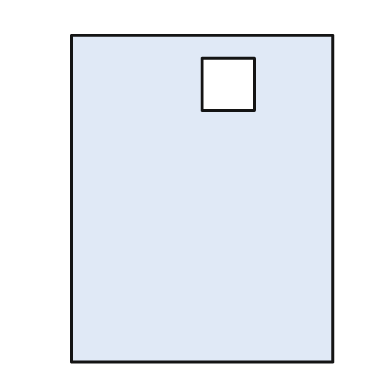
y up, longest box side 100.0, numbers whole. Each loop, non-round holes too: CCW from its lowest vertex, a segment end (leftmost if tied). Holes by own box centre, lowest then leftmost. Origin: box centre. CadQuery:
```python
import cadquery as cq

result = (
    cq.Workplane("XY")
    .moveTo(-40.0, -50.0)
    .lineTo(40.0, -50.0)
    .lineTo(40.0, 50.0)
    .lineTo(-40.0, 50.0)
    .close()
    .moveTo(0.0, 27.0)
    .lineTo(16.0, 27.0)
    .lineTo(16.0, 43.0)
    .lineTo(0.0, 43.0)
    .close()
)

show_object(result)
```